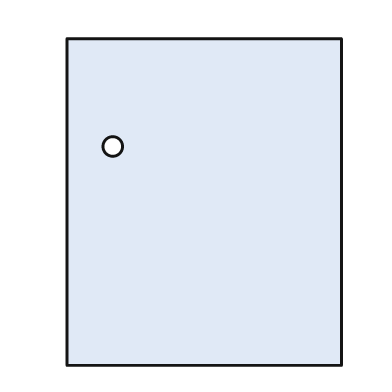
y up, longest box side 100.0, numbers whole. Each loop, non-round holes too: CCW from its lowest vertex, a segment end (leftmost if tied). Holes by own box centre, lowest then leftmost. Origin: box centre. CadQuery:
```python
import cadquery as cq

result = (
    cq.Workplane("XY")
    .moveTo(-42.0, -50.0)
    .lineTo(42.0, -50.0)
    .lineTo(42.0, 50.0)
    .lineTo(-42.0, 50.0)
    .close()
    .moveTo(-28.0, 17.0)
    .circle(3.0)
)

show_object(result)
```